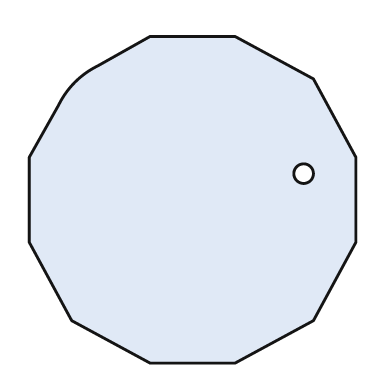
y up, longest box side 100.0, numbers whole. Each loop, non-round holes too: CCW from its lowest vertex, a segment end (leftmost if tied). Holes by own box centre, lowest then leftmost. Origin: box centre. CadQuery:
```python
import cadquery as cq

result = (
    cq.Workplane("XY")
    .moveTo(-13.0, -50.0)
    .lineTo(13.0, -50.0)
    .lineTo(37.0, -37.0)
    .lineTo(50.0, -13.0)
    .lineTo(50.0, 13.0)
    .lineTo(37.0, 37.0)
    .lineTo(13.0, 50.0)
    .lineTo(-13.0, 50.0)
    .lineTo(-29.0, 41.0)
    .threePointArc((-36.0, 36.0), (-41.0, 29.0))
    .lineTo(-50.0, 13.0)
    .lineTo(-50.0, -13.0)
    .lineTo(-37.0, -37.0)
    .close()
    .moveTo(34.0, 8.0)
    .circle(3.0)
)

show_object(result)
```